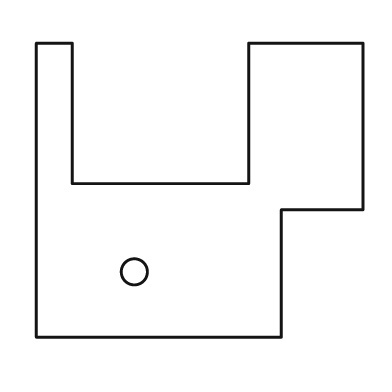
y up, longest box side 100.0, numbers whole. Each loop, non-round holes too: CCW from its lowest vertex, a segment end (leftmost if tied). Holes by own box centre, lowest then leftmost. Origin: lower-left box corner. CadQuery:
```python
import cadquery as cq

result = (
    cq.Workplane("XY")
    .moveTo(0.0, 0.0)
    .lineTo(75.0, 0.0)
    .lineTo(75.0, 39.0)
    .lineTo(100.0, 39.0)
    .lineTo(100.0, 90.0)
    .lineTo(65.0, 90.0)
    .lineTo(65.0, 47.0)
    .lineTo(11.0, 47.0)
    .lineTo(11.0, 90.0)
    .lineTo(0.0, 90.0)
    .close()
    .moveTo(30.0, 20.0)
    .circle(4.0)
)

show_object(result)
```